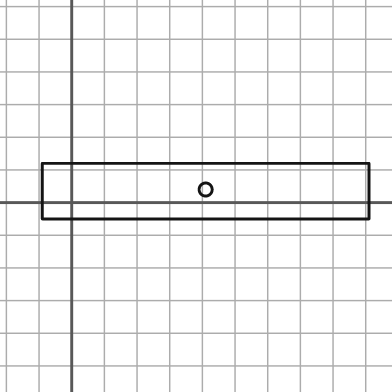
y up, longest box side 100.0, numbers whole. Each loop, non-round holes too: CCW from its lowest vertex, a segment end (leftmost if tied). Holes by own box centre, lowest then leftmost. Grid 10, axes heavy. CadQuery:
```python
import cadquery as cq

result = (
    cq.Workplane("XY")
    .moveTo(-9.0, -5.0)
    .lineTo(91.0, -5.0)
    .lineTo(91.0, 12.0)
    .lineTo(-9.0, 12.0)
    .close()
    .moveTo(41.0, 4.0)
    .circle(2.0)
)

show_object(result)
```